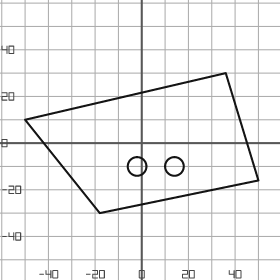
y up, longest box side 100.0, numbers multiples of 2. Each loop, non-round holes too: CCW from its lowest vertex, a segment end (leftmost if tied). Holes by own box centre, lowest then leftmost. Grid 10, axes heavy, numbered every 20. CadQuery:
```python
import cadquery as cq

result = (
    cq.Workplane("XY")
    .moveTo(-18.0, -30.0)
    .lineTo(50.0, -16.0)
    .lineTo(36.0, 30.0)
    .lineTo(-50.0, 10.0)
    .close()
    .moveTo(-2.0, -10.0)
    .circle(4.0)
    .moveTo(14.0, -10.0)
    .circle(4.0)
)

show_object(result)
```